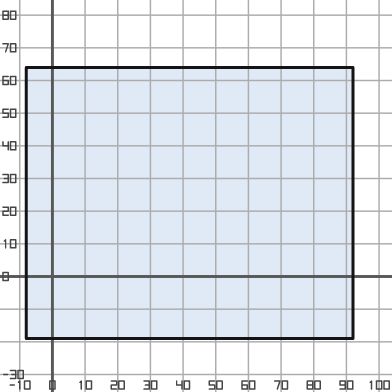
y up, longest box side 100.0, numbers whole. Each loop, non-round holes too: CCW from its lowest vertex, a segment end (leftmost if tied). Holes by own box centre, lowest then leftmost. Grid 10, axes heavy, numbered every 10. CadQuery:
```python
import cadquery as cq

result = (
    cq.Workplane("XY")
    .moveTo(-8.0, -19.0)
    .lineTo(92.0, -19.0)
    .lineTo(92.0, 64.0)
    .lineTo(-8.0, 64.0)
    .close()
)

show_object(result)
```